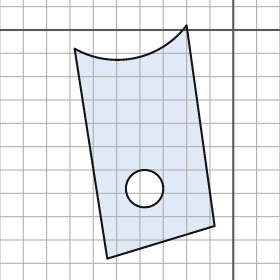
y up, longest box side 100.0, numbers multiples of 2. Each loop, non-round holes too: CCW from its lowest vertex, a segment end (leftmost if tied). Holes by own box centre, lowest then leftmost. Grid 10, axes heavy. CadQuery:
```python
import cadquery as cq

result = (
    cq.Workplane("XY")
    .moveTo(-54.0, -98.0)
    .lineTo(-8.0, -84.0)
    .lineTo(-20.0, 2.0)
    .threePointArc((-42.0, -12.0), (-68.0, -8.0))
    .close()
    .moveTo(-38.0, -68.0)
    .circle(8.0)
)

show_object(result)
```